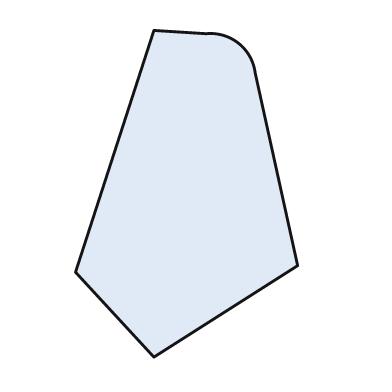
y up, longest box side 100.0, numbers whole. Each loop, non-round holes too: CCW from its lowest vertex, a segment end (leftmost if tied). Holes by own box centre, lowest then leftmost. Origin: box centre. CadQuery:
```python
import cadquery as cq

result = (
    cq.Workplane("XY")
    .moveTo(-10.0, -50.0)
    .lineTo(34.0, -22.0)
    .lineTo(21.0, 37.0)
    .threePointArc((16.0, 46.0), (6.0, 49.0))
    .lineTo(-10.0, 50.0)
    .lineTo(-34.0, -24.0)
    .close()
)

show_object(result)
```